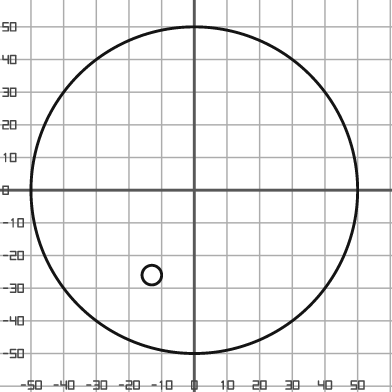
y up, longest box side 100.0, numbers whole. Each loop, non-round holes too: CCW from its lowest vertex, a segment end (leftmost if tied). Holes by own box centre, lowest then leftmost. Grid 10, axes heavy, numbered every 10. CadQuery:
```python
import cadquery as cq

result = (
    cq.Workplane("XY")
    .moveTo(0.0, 0.0)
    .circle(50.0)
    .moveTo(-13.0, -26.0)
    .circle(3.0)
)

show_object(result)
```